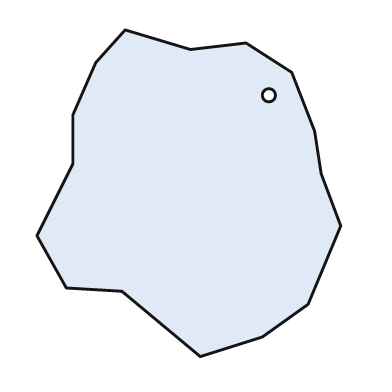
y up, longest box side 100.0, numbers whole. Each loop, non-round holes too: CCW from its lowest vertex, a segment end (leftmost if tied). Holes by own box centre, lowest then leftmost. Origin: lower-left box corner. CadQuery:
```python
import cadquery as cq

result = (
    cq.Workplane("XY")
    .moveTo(50.0, 0.0)
    .lineTo(69.0, 6.0)
    .lineTo(83.0, 16.0)
    .lineTo(93.0, 40.0)
    .lineTo(87.0, 56.0)
    .lineTo(85.0, 69.0)
    .lineTo(78.0, 87.0)
    .lineTo(64.0, 96.0)
    .lineTo(47.0, 94.0)
    .lineTo(27.0, 100.0)
    .lineTo(18.0, 90.0)
    .lineTo(11.0, 74.0)
    .lineTo(11.0, 59.0)
    .lineTo(0.0, 37.0)
    .lineTo(9.0, 21.0)
    .lineTo(26.0, 20.0)
    .close()
    .moveTo(71.0, 80.0)
    .circle(2.0)
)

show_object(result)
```